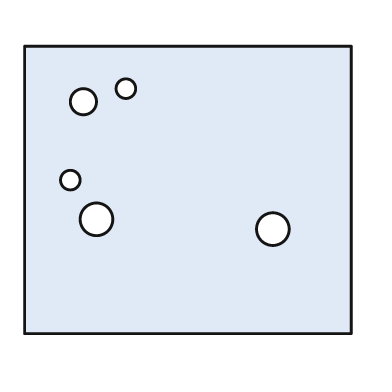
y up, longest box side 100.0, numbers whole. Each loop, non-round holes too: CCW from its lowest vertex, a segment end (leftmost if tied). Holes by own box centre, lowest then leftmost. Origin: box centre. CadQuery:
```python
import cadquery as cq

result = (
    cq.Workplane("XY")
    .moveTo(-50.0, -44.0)
    .lineTo(50.0, -44.0)
    .lineTo(50.0, 44.0)
    .lineTo(-50.0, 44.0)
    .close()
    .moveTo(26.0, -12.0)
    .circle(5.0)
    .moveTo(-28.0, -9.0)
    .circle(5.0)
    .moveTo(-36.0, 3.0)
    .circle(3.0)
    .moveTo(-32.0, 27.0)
    .circle(4.0)
    .moveTo(-19.0, 31.0)
    .circle(3.0)
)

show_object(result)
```